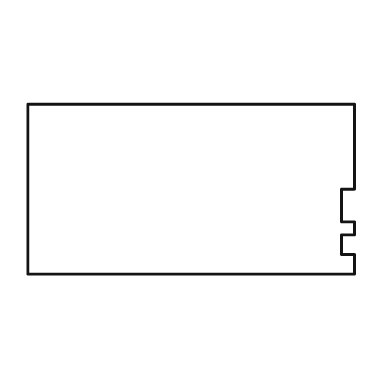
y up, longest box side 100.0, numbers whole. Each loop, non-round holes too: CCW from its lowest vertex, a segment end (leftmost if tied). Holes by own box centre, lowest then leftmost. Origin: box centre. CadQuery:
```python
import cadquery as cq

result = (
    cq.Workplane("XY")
    .moveTo(-50.0, -26.0)
    .lineTo(50.0, -26.0)
    .lineTo(50.0, -20.0)
    .lineTo(46.0, -20.0)
    .lineTo(46.0, -14.0)
    .lineTo(50.0, -14.0)
    .lineTo(50.0, -10.0)
    .lineTo(46.0, -10.0)
    .lineTo(46.0, 0.0)
    .lineTo(50.0, 0.0)
    .lineTo(50.0, 26.0)
    .lineTo(-50.0, 26.0)
    .close()
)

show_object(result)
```